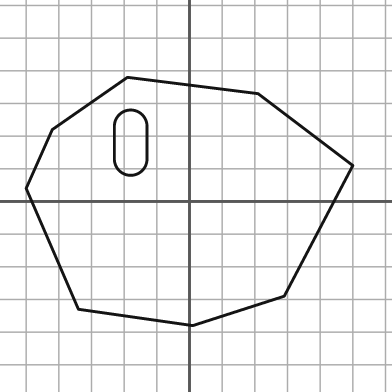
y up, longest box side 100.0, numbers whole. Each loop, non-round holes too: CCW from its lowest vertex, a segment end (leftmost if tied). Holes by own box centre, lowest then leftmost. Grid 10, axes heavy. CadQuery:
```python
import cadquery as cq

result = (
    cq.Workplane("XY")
    .moveTo(1.0, -38.0)
    .lineTo(29.0, -29.0)
    .lineTo(50.0, 11.0)
    .lineTo(21.0, 33.0)
    .lineTo(-19.0, 38.0)
    .lineTo(-42.0, 22.0)
    .lineTo(-50.0, 4.0)
    .lineTo(-34.0, -33.0)
    .close()
    .moveTo(-23.0, 13.0)
    .threePointArc((-18.0, 8.0), (-13.0, 13.0))
    .lineTo(-13.0, 23.0)
    .threePointArc((-18.0, 28.0), (-23.0, 23.0))
    .close()
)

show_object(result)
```